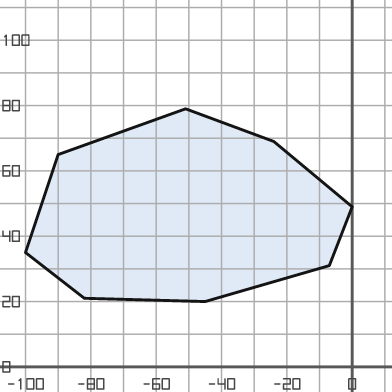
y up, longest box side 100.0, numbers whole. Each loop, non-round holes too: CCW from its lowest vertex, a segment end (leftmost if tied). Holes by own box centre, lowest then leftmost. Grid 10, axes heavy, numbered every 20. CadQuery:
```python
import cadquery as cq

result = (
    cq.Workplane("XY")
    .moveTo(-45.0, 20.0)
    .lineTo(-7.0, 31.0)
    .lineTo(0.0, 49.0)
    .lineTo(-24.0, 69.0)
    .lineTo(-51.0, 79.0)
    .lineTo(-90.0, 65.0)
    .lineTo(-100.0, 35.0)
    .lineTo(-82.0, 21.0)
    .close()
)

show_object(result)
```